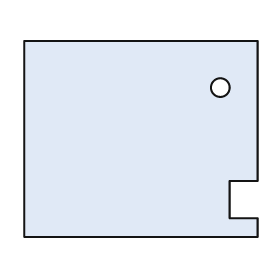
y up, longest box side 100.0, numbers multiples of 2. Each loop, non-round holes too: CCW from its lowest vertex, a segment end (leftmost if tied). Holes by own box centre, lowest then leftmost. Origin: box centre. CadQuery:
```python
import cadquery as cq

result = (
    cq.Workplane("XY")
    .moveTo(-50.0, -42.0)
    .lineTo(50.0, -42.0)
    .lineTo(50.0, -34.0)
    .lineTo(38.0, -34.0)
    .lineTo(38.0, -18.0)
    .lineTo(50.0, -18.0)
    .lineTo(50.0, 42.0)
    .lineTo(-50.0, 42.0)
    .close()
    .moveTo(34.0, 22.0)
    .circle(4.0)
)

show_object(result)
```